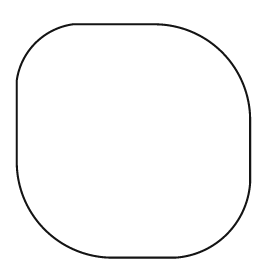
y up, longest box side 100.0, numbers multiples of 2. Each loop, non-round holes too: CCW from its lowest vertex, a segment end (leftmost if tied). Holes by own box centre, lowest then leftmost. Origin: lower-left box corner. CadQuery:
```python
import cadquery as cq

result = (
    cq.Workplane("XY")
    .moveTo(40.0, 0.0)
    .lineTo(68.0, 0.0)
    .threePointArc((90.0, 10.0), (100.0, 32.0))
    .lineTo(100.0, 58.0)
    .threePointArc((88.0, 88.0), (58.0, 100.0))
    .lineTo(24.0, 100.0)
    .threePointArc((8.0, 92.0), (0.0, 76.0))
    .lineTo(0.0, 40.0)
    .threePointArc((12.0, 12.0), (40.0, 0.0))
    .close()
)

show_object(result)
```